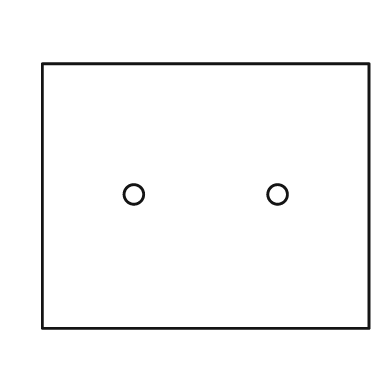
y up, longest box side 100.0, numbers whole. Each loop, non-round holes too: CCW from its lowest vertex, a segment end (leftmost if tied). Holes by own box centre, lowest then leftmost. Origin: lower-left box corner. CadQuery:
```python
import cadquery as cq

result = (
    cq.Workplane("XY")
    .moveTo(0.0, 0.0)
    .lineTo(100.0, 0.0)
    .lineTo(100.0, 81.0)
    .lineTo(0.0, 81.0)
    .close()
    .moveTo(28.0, 41.0)
    .circle(3.0)
    .moveTo(72.0, 41.0)
    .circle(3.0)
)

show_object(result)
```